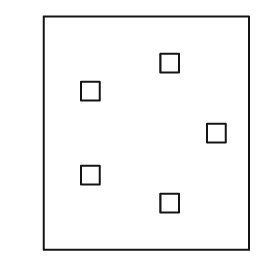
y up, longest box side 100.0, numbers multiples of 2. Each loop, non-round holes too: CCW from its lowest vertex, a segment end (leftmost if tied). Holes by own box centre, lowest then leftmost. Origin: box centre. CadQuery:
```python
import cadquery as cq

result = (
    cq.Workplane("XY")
    .moveTo(-44.0, -50.0)
    .lineTo(44.0, -50.0)
    .lineTo(44.0, 50.0)
    .lineTo(-44.0, 50.0)
    .close()
    .moveTo(6.0, -34.0)
    .lineTo(14.0, -34.0)
    .lineTo(14.0, -26.0)
    .lineTo(6.0, -26.0)
    .close()
    .moveTo(-28.0, -22.0)
    .lineTo(-20.0, -22.0)
    .lineTo(-20.0, -14.0)
    .lineTo(-28.0, -14.0)
    .close()
    .moveTo(26.0, -4.0)
    .lineTo(34.0, -4.0)
    .lineTo(34.0, 4.0)
    .lineTo(26.0, 4.0)
    .close()
    .moveTo(-28.0, 14.0)
    .lineTo(-20.0, 14.0)
    .lineTo(-20.0, 22.0)
    .lineTo(-28.0, 22.0)
    .close()
    .moveTo(6.0, 26.0)
    .lineTo(14.0, 26.0)
    .lineTo(14.0, 34.0)
    .lineTo(6.0, 34.0)
    .close()
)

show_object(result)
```